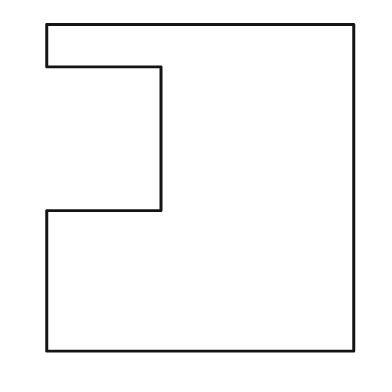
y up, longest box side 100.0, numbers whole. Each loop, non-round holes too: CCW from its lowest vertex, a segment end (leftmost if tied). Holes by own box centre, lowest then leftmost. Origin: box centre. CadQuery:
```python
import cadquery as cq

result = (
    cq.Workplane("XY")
    .moveTo(-47.0, -50.0)
    .lineTo(47.0, -50.0)
    .lineTo(47.0, 50.0)
    .lineTo(-47.0, 50.0)
    .lineTo(-47.0, 37.0)
    .lineTo(-12.0, 37.0)
    .lineTo(-12.0, -7.0)
    .lineTo(-47.0, -7.0)
    .close()
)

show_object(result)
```